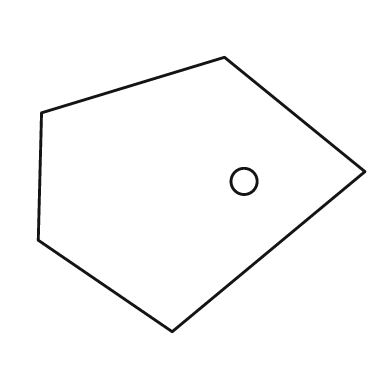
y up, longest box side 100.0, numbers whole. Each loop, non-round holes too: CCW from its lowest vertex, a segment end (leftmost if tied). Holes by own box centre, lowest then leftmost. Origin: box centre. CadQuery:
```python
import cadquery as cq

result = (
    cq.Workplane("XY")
    .moveTo(-9.0, -42.0)
    .lineTo(50.0, 7.0)
    .lineTo(7.0, 42.0)
    .lineTo(-49.0, 25.0)
    .lineTo(-50.0, -14.0)
    .close()
    .moveTo(13.0, 4.0)
    .circle(4.0)
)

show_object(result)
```